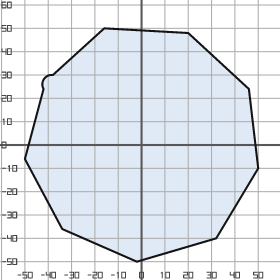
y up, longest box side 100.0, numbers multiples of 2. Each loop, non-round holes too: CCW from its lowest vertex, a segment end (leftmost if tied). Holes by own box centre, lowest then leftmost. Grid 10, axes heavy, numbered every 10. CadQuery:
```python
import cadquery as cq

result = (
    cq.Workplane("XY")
    .moveTo(-2.0, -50.0)
    .lineTo(32.0, -40.0)
    .lineTo(50.0, -10.0)
    .lineTo(46.0, 24.0)
    .lineTo(20.0, 48.0)
    .lineTo(-16.0, 50.0)
    .lineTo(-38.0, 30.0)
    .threePointArc((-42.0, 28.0), (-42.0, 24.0))
    .lineTo(-50.0, -6.0)
    .lineTo(-34.0, -36.0)
    .close()
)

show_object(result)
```